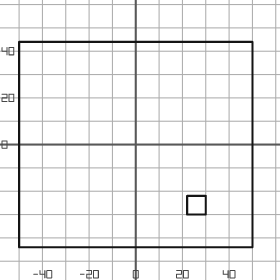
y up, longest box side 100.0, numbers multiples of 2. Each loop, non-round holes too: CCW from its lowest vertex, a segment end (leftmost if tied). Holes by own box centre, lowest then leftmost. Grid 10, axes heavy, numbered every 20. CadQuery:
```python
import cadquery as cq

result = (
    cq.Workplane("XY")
    .moveTo(-50.0, -44.0)
    .lineTo(50.0, -44.0)
    .lineTo(50.0, 44.0)
    .lineTo(-50.0, 44.0)
    .close()
    .moveTo(22.0, -30.0)
    .lineTo(30.0, -30.0)
    .lineTo(30.0, -22.0)
    .lineTo(22.0, -22.0)
    .close()
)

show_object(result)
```